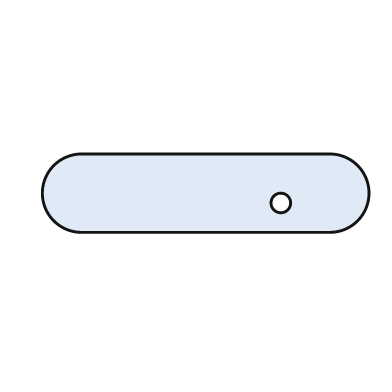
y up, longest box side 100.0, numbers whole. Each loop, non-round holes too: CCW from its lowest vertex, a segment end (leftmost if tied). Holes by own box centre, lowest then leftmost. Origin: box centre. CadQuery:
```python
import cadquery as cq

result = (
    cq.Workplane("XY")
    .moveTo(-38.0, -12.0)
    .lineTo(38.0, -12.0)
    .threePointArc((50.0, 0.0), (38.0, 12.0))
    .lineTo(-38.0, 12.0)
    .threePointArc((-50.0, 0.0), (-38.0, -12.0))
    .close()
    .moveTo(23.0, -3.0)
    .circle(3.0)
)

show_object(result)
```